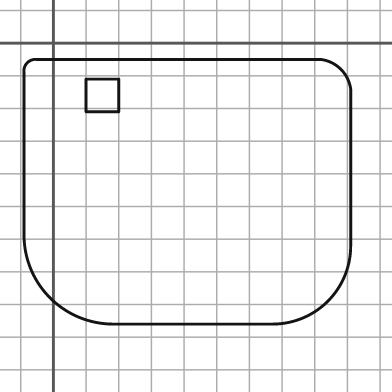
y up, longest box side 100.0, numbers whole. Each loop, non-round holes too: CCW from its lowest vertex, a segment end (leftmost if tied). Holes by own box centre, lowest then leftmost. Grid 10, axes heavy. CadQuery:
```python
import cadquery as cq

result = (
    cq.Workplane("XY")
    .moveTo(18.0, -86.0)
    .lineTo(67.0, -86.0)
    .threePointArc((84.0, -79.0), (91.0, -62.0))
    .lineTo(91.0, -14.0)
    .threePointArc((88.0, -8.0), (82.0, -5.0))
    .lineTo(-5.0, -5.0)
    .threePointArc((-8.0, -6.0), (-9.0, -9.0))
    .lineTo(-9.0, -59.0)
    .threePointArc((-1.0, -78.0), (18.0, -86.0))
    .close()
    .moveTo(10.0, -21.0)
    .lineTo(20.0, -21.0)
    .lineTo(20.0, -11.0)
    .lineTo(10.0, -11.0)
    .close()
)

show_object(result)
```